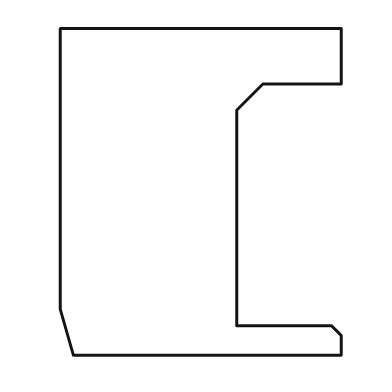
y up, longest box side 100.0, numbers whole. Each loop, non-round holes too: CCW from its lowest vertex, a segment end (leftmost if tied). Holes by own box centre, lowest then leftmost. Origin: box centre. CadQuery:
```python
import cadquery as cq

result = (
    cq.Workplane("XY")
    .moveTo(-39.0, -50.0)
    .lineTo(43.0, -50.0)
    .lineTo(43.0, -44.0)
    .lineTo(40.0, -41.0)
    .lineTo(11.0, -41.0)
    .lineTo(11.0, 25.0)
    .lineTo(19.0, 33.0)
    .lineTo(43.0, 33.0)
    .lineTo(43.0, 50.0)
    .lineTo(-43.0, 50.0)
    .lineTo(-43.0, -36.0)
    .close()
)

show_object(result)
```